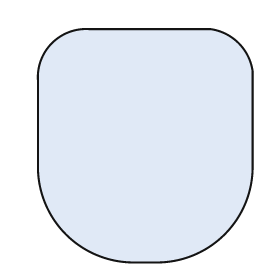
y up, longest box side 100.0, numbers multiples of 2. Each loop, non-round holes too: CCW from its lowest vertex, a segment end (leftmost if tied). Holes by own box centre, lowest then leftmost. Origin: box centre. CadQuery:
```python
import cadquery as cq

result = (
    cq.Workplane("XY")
    .moveTo(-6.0, -50.0)
    .lineTo(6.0, -50.0)
    .threePointArc((34.0, -38.0), (46.0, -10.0))
    .lineTo(46.0, 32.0)
    .threePointArc((40.0, 44.0), (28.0, 50.0))
    .lineTo(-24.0, 50.0)
    .threePointArc((-40.0, 44.0), (-46.0, 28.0))
    .lineTo(-46.0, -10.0)
    .threePointArc((-34.0, -38.0), (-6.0, -50.0))
    .close()
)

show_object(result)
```